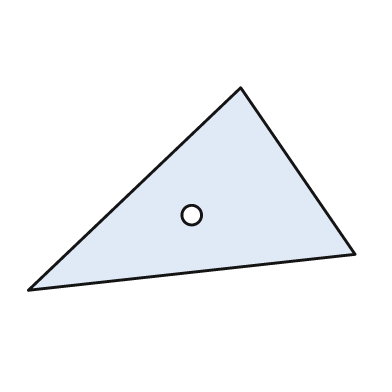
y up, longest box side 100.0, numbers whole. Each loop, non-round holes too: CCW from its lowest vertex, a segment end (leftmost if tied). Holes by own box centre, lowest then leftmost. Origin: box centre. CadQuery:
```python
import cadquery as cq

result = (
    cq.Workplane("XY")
    .moveTo(-50.0, -31.0)
    .lineTo(50.0, -20.0)
    .lineTo(15.0, 31.0)
    .close()
    .moveTo(0.0, -8.0)
    .circle(3.0)
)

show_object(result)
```